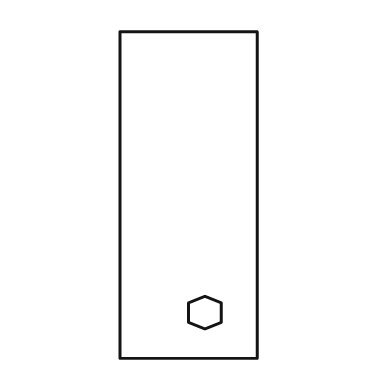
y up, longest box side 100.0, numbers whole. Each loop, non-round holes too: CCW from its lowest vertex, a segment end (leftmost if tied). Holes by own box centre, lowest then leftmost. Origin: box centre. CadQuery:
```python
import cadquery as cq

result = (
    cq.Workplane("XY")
    .moveTo(-21.0, -50.0)
    .lineTo(21.0, -50.0)
    .lineTo(21.0, 50.0)
    .lineTo(-21.0, 50.0)
    .close()
    .moveTo(5.0, -41.0)
    .lineTo(10.0, -39.0)
    .lineTo(10.0, -33.0)
    .lineTo(5.0, -31.0)
    .lineTo(0.0, -33.0)
    .lineTo(0.0, -39.0)
    .close()
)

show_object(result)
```